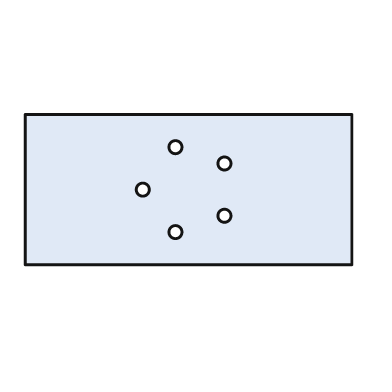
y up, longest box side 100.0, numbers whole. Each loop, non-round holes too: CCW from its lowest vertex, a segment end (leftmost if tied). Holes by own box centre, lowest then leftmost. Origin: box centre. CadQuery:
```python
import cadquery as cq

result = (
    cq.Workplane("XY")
    .moveTo(-50.0, -23.0)
    .lineTo(50.0, -23.0)
    .lineTo(50.0, 23.0)
    .lineTo(-50.0, 23.0)
    .close()
    .moveTo(-4.0, -13.0)
    .circle(2.0)
    .moveTo(11.0, -8.0)
    .circle(2.0)
    .moveTo(-14.0, 0.0)
    .circle(2.0)
    .moveTo(11.0, 8.0)
    .circle(2.0)
    .moveTo(-4.0, 13.0)
    .circle(2.0)
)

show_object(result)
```